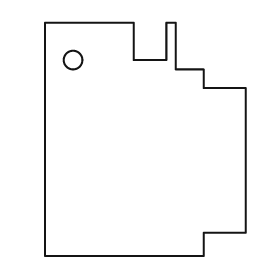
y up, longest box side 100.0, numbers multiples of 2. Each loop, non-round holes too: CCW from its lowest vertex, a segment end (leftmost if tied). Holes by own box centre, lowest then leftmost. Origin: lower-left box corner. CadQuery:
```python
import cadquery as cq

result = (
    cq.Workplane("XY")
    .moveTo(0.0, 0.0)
    .lineTo(68.0, 0.0)
    .lineTo(68.0, 10.0)
    .lineTo(86.0, 10.0)
    .lineTo(86.0, 72.0)
    .lineTo(68.0, 72.0)
    .lineTo(68.0, 80.0)
    .lineTo(56.0, 80.0)
    .lineTo(56.0, 100.0)
    .lineTo(52.0, 100.0)
    .lineTo(52.0, 84.0)
    .lineTo(38.0, 84.0)
    .lineTo(38.0, 100.0)
    .lineTo(0.0, 100.0)
    .close()
    .moveTo(12.0, 84.0)
    .circle(4.0)
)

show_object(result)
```